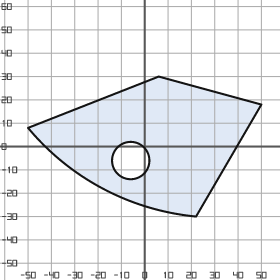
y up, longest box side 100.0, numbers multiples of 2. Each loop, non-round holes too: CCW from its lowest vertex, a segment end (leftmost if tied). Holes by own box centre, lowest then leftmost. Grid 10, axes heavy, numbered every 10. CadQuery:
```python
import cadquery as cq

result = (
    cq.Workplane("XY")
    .moveTo(22.0, -30.0)
    .lineTo(50.0, 18.0)
    .lineTo(6.0, 30.0)
    .lineTo(-50.0, 8.0)
    .threePointArc((-18.0, -18.0), (22.0, -30.0))
    .close()
    .moveTo(-6.0, -6.0)
    .circle(8.0)
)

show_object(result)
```